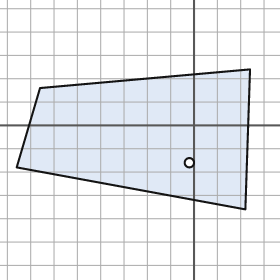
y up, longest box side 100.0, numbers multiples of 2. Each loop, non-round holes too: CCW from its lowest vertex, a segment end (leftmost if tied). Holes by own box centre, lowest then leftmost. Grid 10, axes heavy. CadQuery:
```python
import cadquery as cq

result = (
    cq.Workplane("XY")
    .moveTo(22.0, -36.0)
    .lineTo(24.0, 24.0)
    .lineTo(-66.0, 16.0)
    .lineTo(-76.0, -18.0)
    .close()
    .moveTo(-2.0, -16.0)
    .circle(2.0)
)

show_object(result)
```